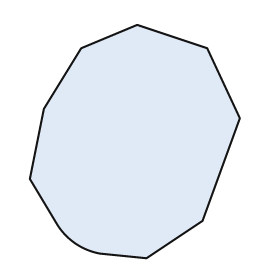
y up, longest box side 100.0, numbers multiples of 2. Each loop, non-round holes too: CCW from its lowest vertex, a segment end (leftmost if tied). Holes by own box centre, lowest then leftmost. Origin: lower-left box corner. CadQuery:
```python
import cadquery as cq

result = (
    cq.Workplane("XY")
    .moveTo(50.0, 0.0)
    .lineTo(74.0, 16.0)
    .lineTo(90.0, 60.0)
    .lineTo(76.0, 90.0)
    .lineTo(46.0, 100.0)
    .lineTo(22.0, 90.0)
    .lineTo(6.0, 64.0)
    .lineTo(0.0, 34.0)
    .lineTo(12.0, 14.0)
    .threePointArc((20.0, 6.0), (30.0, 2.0))
    .close()
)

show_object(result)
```